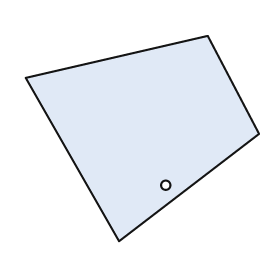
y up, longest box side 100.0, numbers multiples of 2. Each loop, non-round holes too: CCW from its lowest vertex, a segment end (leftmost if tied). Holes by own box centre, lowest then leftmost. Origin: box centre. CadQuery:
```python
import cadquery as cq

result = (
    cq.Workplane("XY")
    .moveTo(-10.0, -44.0)
    .lineTo(50.0, 2.0)
    .lineTo(28.0, 44.0)
    .lineTo(-50.0, 26.0)
    .close()
    .moveTo(10.0, -20.0)
    .circle(2.0)
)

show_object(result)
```